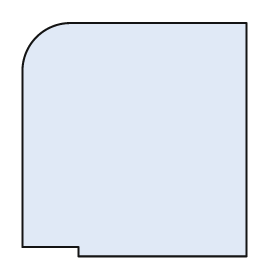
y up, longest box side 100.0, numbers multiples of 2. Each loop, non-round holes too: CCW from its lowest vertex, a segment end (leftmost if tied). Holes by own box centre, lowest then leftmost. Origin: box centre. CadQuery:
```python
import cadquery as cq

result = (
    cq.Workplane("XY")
    .moveTo(-24.0, -50.0)
    .lineTo(48.0, -50.0)
    .lineTo(48.0, 50.0)
    .lineTo(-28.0, 50.0)
    .threePointArc((-42.0, 44.0), (-48.0, 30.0))
    .lineTo(-48.0, -46.0)
    .lineTo(-24.0, -46.0)
    .close()
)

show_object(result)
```